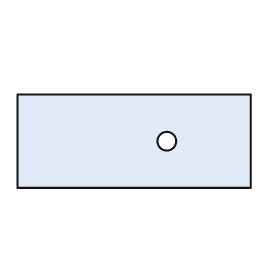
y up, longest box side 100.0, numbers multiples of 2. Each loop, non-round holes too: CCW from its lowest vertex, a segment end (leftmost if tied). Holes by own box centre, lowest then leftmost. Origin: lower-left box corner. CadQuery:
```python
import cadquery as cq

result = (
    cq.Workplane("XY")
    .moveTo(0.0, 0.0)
    .lineTo(100.0, 0.0)
    .lineTo(100.0, 40.0)
    .lineTo(0.0, 40.0)
    .close()
    .moveTo(64.0, 20.0)
    .circle(4.0)
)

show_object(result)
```